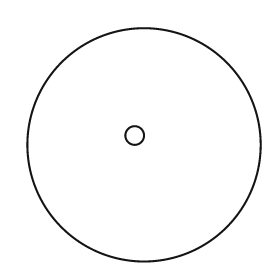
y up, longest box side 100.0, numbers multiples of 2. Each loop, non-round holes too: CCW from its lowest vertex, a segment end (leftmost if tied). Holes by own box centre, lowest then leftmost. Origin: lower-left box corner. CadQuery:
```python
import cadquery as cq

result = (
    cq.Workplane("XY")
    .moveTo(50.0, 50.0)
    .circle(50.0)
    .moveTo(46.0, 54.0)
    .circle(4.0)
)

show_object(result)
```